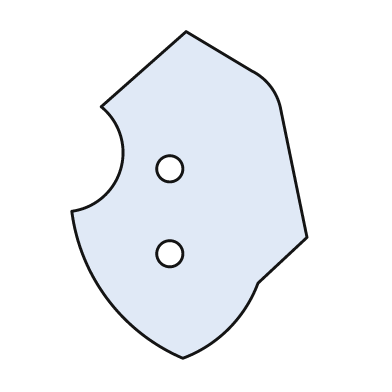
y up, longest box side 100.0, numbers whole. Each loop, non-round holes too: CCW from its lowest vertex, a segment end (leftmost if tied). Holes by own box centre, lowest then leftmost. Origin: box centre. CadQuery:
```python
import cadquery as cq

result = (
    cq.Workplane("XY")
    .moveTo(-2.0, -50.0)
    .threePointArc((12.0, -41.0), (21.0, -27.0))
    .lineTo(36.0, -13.0)
    .lineTo(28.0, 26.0)
    .threePointArc((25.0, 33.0), (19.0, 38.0))
    .lineTo(-1.0, 50.0)
    .lineTo(-27.0, 27.0)
    .threePointArc((-21.0, 8.0), (-36.0, -5.0))
    .threePointArc((-25.0, -32.0), (-2.0, -50.0))
    .close()
    .moveTo(-6.0, -18.0)
    .circle(4.0)
    .moveTo(-6.0, 8.0)
    .circle(4.0)
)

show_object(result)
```